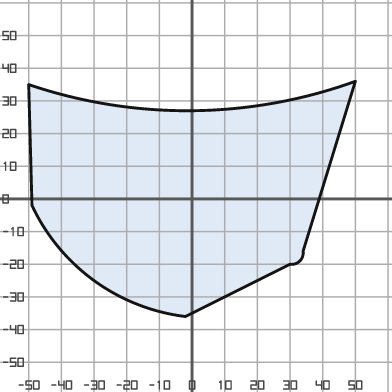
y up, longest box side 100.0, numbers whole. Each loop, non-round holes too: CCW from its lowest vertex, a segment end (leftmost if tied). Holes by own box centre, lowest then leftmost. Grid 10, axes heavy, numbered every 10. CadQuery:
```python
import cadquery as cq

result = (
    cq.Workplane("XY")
    .moveTo(-2.0, -36.0)
    .lineTo(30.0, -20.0)
    .threePointArc((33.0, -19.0), (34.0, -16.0))
    .lineTo(50.0, 36.0)
    .threePointArc((0.0, 27.0), (-50.0, 35.0))
    .lineTo(-49.0, -2.0)
    .threePointArc((-30.0, -25.0), (-2.0, -36.0))
    .close()
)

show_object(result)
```